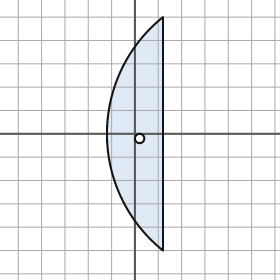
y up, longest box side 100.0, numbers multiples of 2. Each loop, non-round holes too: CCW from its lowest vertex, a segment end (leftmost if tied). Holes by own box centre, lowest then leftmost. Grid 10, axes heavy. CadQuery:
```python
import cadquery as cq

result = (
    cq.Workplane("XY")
    .moveTo(12.0, -50.0)
    .lineTo(12.0, 50.0)
    .threePointArc((-12.0, 0.0), (12.0, -50.0))
    .close()
    .moveTo(2.0, -2.0)
    .circle(2.0)
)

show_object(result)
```